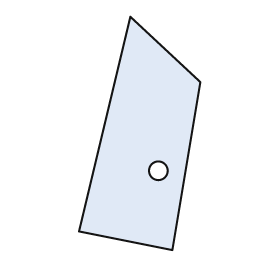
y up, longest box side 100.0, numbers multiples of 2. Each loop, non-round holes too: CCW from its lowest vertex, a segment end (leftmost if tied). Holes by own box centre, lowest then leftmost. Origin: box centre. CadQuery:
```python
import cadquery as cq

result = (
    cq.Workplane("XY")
    .moveTo(14.0, -50.0)
    .lineTo(26.0, 22.0)
    .lineTo(-4.0, 50.0)
    .lineTo(-26.0, -42.0)
    .close()
    .moveTo(8.0, -16.0)
    .circle(4.0)
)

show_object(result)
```